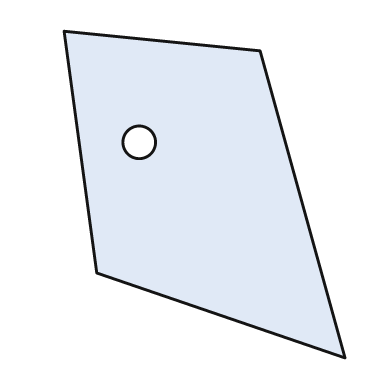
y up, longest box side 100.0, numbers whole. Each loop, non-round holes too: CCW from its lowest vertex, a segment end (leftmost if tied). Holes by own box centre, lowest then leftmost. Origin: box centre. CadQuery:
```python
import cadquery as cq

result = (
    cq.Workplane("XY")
    .moveTo(43.0, -50.0)
    .lineTo(17.0, 44.0)
    .lineTo(-43.0, 50.0)
    .lineTo(-33.0, -24.0)
    .close()
    .moveTo(-20.0, 16.0)
    .circle(5.0)
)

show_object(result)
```